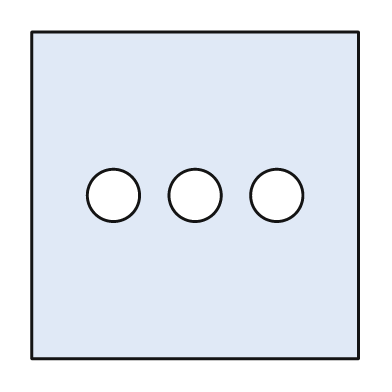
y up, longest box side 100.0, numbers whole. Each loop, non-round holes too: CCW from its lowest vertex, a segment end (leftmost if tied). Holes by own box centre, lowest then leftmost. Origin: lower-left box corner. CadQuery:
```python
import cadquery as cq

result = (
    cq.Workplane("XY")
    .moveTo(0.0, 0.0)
    .lineTo(100.0, 0.0)
    .lineTo(100.0, 100.0)
    .lineTo(0.0, 100.0)
    .close()
    .moveTo(25.0, 50.0)
    .circle(8.0)
    .moveTo(50.0, 50.0)
    .circle(8.0)
    .moveTo(75.0, 50.0)
    .circle(8.0)
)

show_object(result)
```